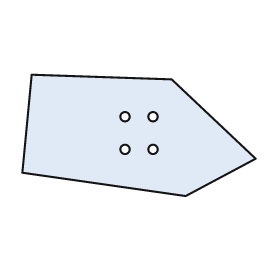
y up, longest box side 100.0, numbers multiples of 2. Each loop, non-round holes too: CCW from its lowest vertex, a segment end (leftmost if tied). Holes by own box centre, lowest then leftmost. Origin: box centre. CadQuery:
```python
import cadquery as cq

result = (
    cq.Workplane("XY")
    .moveTo(20.0, -26.0)
    .lineTo(50.0, -10.0)
    .lineTo(14.0, 24.0)
    .lineTo(-46.0, 26.0)
    .lineTo(-50.0, -16.0)
    .close()
    .moveTo(-6.0, -6.0)
    .circle(2.0)
    .moveTo(6.0, -6.0)
    .circle(2.0)
    .moveTo(-6.0, 8.0)
    .circle(2.0)
    .moveTo(6.0, 8.0)
    .circle(2.0)
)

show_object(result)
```